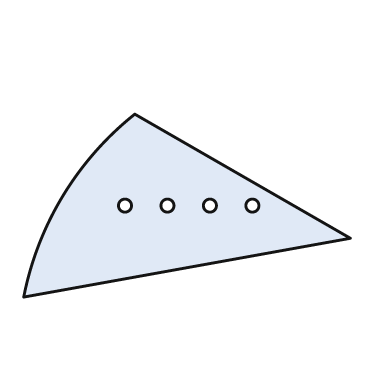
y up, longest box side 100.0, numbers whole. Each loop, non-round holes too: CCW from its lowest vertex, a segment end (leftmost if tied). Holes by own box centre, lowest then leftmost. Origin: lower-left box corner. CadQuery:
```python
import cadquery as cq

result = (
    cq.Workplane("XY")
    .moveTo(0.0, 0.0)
    .lineTo(100.0, 18.0)
    .lineTo(34.0, 56.0)
    .threePointArc((12.0, 31.0), (0.0, 0.0))
    .close()
    .moveTo(31.0, 28.0)
    .circle(2.0)
    .moveTo(44.0, 28.0)
    .circle(2.0)
    .moveTo(57.0, 28.0)
    .circle(2.0)
    .moveTo(70.0, 28.0)
    .circle(2.0)
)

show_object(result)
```